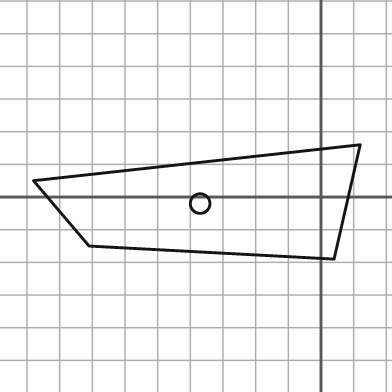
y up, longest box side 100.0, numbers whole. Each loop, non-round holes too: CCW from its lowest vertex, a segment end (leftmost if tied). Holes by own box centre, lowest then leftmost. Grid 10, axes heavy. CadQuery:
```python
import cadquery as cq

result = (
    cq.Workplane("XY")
    .moveTo(4.0, -19.0)
    .lineTo(12.0, 16.0)
    .lineTo(-88.0, 5.0)
    .lineTo(-71.0, -15.0)
    .close()
    .moveTo(-37.0, -2.0)
    .circle(3.0)
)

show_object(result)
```